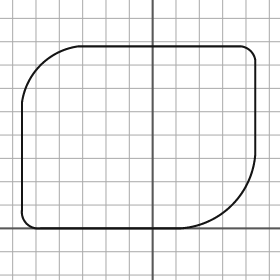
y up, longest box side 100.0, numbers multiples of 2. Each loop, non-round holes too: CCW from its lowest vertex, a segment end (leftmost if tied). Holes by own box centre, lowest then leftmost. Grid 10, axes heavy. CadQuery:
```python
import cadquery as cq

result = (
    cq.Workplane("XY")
    .moveTo(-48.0, 0.0)
    .lineTo(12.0, 0.0)
    .threePointArc((34.0, 10.0), (44.0, 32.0))
    .lineTo(44.0, 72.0)
    .threePointArc((42.0, 76.0), (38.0, 78.0))
    .lineTo(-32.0, 78.0)
    .threePointArc((-48.0, 70.0), (-56.0, 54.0))
    .lineTo(-56.0, 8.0)
    .threePointArc((-54.0, 2.0), (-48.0, 0.0))
    .close()
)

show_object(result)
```